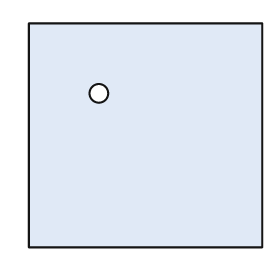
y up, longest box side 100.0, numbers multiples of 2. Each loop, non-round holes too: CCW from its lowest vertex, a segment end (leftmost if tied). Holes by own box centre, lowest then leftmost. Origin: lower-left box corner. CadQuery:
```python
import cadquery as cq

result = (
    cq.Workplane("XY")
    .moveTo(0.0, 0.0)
    .lineTo(100.0, 0.0)
    .lineTo(100.0, 96.0)
    .lineTo(0.0, 96.0)
    .close()
    .moveTo(30.0, 66.0)
    .circle(4.0)
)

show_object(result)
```